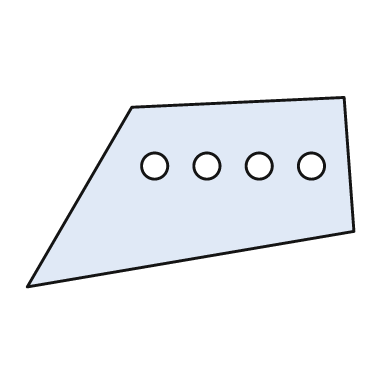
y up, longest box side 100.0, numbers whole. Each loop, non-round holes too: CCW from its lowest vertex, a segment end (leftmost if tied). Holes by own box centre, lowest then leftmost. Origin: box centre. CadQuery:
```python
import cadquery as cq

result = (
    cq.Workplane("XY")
    .moveTo(-50.0, -29.0)
    .lineTo(50.0, -12.0)
    .lineTo(47.0, 29.0)
    .lineTo(-18.0, 26.0)
    .close()
    .moveTo(-11.0, 8.0)
    .circle(4.0)
    .moveTo(5.0, 8.0)
    .circle(4.0)
    .moveTo(21.0, 8.0)
    .circle(4.0)
    .moveTo(37.0, 8.0)
    .circle(4.0)
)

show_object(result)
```